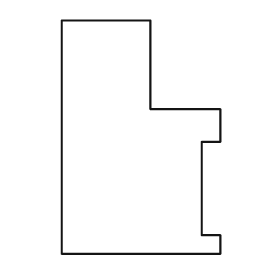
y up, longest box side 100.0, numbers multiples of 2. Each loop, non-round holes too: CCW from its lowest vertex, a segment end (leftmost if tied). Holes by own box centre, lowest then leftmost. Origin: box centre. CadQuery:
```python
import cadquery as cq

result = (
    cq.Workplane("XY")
    .moveTo(-34.0, -50.0)
    .lineTo(34.0, -50.0)
    .lineTo(34.0, -42.0)
    .lineTo(26.0, -42.0)
    .lineTo(26.0, -2.0)
    .lineTo(34.0, -2.0)
    .lineTo(34.0, 12.0)
    .lineTo(4.0, 12.0)
    .lineTo(4.0, 50.0)
    .lineTo(-34.0, 50.0)
    .close()
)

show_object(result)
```